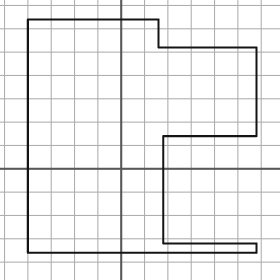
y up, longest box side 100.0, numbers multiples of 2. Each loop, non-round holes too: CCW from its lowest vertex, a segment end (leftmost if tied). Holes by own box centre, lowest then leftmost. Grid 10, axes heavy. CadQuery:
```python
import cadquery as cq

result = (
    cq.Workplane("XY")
    .moveTo(-40.0, -36.0)
    .lineTo(58.0, -36.0)
    .lineTo(58.0, -32.0)
    .lineTo(18.0, -32.0)
    .lineTo(18.0, 14.0)
    .lineTo(58.0, 14.0)
    .lineTo(58.0, 52.0)
    .lineTo(16.0, 52.0)
    .lineTo(16.0, 64.0)
    .lineTo(-40.0, 64.0)
    .close()
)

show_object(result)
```